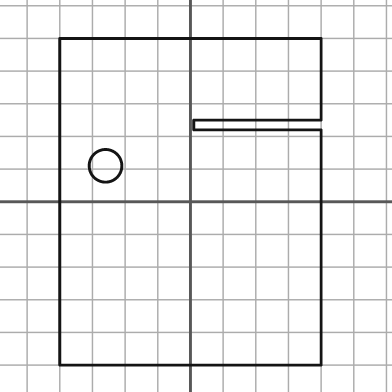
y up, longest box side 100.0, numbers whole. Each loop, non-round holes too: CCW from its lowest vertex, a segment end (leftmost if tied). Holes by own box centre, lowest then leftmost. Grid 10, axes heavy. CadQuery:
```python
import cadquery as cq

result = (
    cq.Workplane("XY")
    .moveTo(-40.0, -50.0)
    .lineTo(40.0, -50.0)
    .lineTo(40.0, 22.0)
    .lineTo(1.0, 22.0)
    .lineTo(1.0, 25.0)
    .lineTo(40.0, 25.0)
    .lineTo(40.0, 50.0)
    .lineTo(-40.0, 50.0)
    .close()
    .moveTo(-26.0, 11.0)
    .circle(5.0)
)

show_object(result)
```